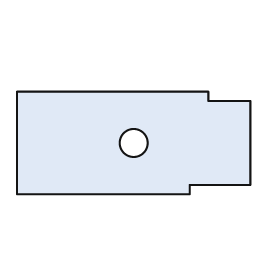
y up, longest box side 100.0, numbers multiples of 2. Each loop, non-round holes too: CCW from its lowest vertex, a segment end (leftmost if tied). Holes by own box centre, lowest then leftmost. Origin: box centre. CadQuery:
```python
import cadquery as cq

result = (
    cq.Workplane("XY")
    .moveTo(-50.0, -22.0)
    .lineTo(24.0, -22.0)
    .lineTo(24.0, -18.0)
    .lineTo(50.0, -18.0)
    .lineTo(50.0, 18.0)
    .lineTo(32.0, 18.0)
    .lineTo(32.0, 22.0)
    .lineTo(-50.0, 22.0)
    .close()
    .moveTo(0.0, 0.0)
    .circle(6.0)
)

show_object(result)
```